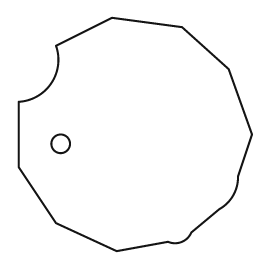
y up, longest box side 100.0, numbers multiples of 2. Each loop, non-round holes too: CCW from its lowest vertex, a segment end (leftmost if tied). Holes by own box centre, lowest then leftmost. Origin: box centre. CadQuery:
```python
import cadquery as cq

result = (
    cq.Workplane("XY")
    .moveTo(-8.0, -50.0)
    .lineTo(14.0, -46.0)
    .threePointArc((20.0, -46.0), (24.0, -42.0))
    .lineTo(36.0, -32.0)
    .threePointArc((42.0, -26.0), (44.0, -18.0))
    .lineTo(50.0, 0.0)
    .lineTo(40.0, 28.0)
    .lineTo(20.0, 46.0)
    .lineTo(-10.0, 50.0)
    .lineTo(-34.0, 38.0)
    .threePointArc((-36.0, 22.0), (-50.0, 14.0))
    .lineTo(-50.0, -14.0)
    .lineTo(-34.0, -38.0)
    .close()
    .moveTo(-32.0, -4.0)
    .circle(4.0)
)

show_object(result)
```